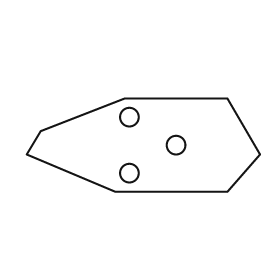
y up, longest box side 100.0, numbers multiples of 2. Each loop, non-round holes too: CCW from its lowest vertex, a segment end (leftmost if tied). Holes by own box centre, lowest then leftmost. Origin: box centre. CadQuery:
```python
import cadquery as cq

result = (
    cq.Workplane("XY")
    .moveTo(-12.0, -20.0)
    .lineTo(36.0, -20.0)
    .lineTo(50.0, -4.0)
    .lineTo(36.0, 20.0)
    .lineTo(-8.0, 20.0)
    .lineTo(-44.0, 6.0)
    .lineTo(-50.0, -4.0)
    .close()
    .moveTo(-6.0, -12.0)
    .circle(4.0)
    .moveTo(14.0, 0.0)
    .circle(4.0)
    .moveTo(-6.0, 12.0)
    .circle(4.0)
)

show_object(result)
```